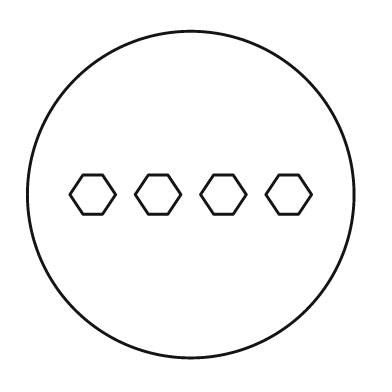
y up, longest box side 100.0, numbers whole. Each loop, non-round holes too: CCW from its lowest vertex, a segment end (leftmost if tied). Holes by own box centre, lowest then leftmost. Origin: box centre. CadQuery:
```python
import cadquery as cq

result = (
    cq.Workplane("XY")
    .moveTo(0.0, 0.0)
    .circle(50.0)
    .moveTo(-33.0, -6.0)
    .lineTo(-27.0, -6.0)
    .lineTo(-23.0, 0.0)
    .lineTo(-27.0, 6.0)
    .lineTo(-33.0, 6.0)
    .lineTo(-37.0, 0.0)
    .close()
    .moveTo(-13.0, -6.0)
    .lineTo(-7.0, -6.0)
    .lineTo(-3.0, 0.0)
    .lineTo(-7.0, 6.0)
    .lineTo(-13.0, 6.0)
    .lineTo(-17.0, 0.0)
    .close()
    .moveTo(7.0, -6.0)
    .lineTo(13.0, -6.0)
    .lineTo(17.0, 0.0)
    .lineTo(13.0, 6.0)
    .lineTo(7.0, 6.0)
    .lineTo(3.0, 0.0)
    .close()
    .moveTo(27.0, -6.0)
    .lineTo(33.0, -6.0)
    .lineTo(37.0, 0.0)
    .lineTo(33.0, 6.0)
    .lineTo(27.0, 6.0)
    .lineTo(23.0, 0.0)
    .close()
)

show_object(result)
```